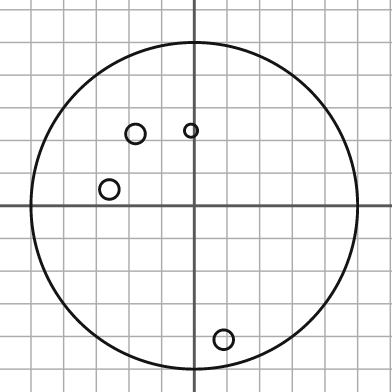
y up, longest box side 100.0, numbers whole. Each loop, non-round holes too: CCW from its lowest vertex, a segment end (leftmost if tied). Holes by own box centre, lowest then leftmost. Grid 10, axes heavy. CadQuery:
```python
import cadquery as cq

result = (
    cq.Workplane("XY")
    .moveTo(0.0, 0.0)
    .circle(50.0)
    .moveTo(9.0, -41.0)
    .circle(3.0)
    .moveTo(-26.0, 5.0)
    .circle(3.0)
    .moveTo(-18.0, 22.0)
    .circle(3.0)
    .moveTo(-1.0, 23.0)
    .circle(2.0)
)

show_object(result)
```